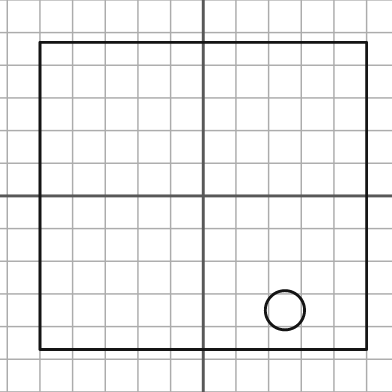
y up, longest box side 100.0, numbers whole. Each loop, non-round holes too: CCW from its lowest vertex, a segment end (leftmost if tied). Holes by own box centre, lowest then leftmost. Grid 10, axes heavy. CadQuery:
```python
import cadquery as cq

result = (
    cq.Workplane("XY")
    .moveTo(-50.0, -47.0)
    .lineTo(50.0, -47.0)
    .lineTo(50.0, 47.0)
    .lineTo(-50.0, 47.0)
    .close()
    .moveTo(25.0, -35.0)
    .circle(6.0)
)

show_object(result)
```